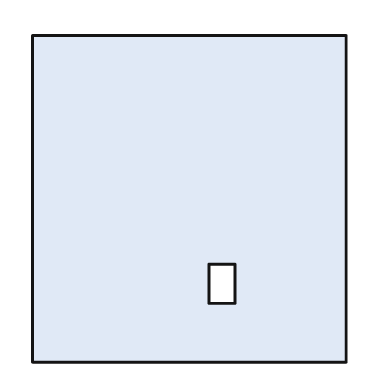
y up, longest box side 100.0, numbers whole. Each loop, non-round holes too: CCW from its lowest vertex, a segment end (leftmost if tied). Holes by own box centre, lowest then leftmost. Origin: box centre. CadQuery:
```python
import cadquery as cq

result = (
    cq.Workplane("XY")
    .moveTo(-48.0, -50.0)
    .lineTo(48.0, -50.0)
    .lineTo(48.0, 50.0)
    .lineTo(-48.0, 50.0)
    .close()
    .moveTo(6.0, -32.0)
    .lineTo(14.0, -32.0)
    .lineTo(14.0, -20.0)
    .lineTo(6.0, -20.0)
    .close()
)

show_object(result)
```